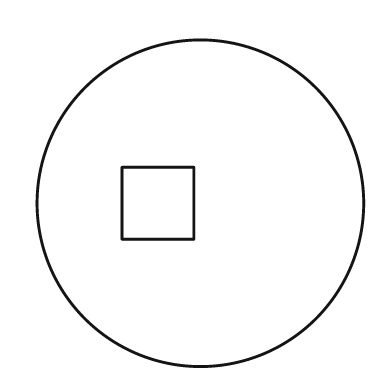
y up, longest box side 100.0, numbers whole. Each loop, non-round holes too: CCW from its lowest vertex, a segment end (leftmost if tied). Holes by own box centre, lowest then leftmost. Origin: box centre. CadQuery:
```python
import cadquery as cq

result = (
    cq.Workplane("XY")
    .moveTo(0.0, 0.0)
    .circle(50.0)
    .moveTo(-24.0, -11.0)
    .lineTo(-2.0, -11.0)
    .lineTo(-2.0, 11.0)
    .lineTo(-24.0, 11.0)
    .close()
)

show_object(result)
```